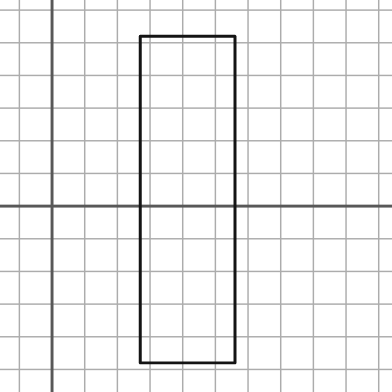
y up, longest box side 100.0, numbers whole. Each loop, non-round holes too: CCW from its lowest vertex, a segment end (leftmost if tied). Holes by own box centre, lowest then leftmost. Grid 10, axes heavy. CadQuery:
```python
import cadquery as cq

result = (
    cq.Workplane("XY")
    .moveTo(27.0, -48.0)
    .lineTo(56.0, -48.0)
    .lineTo(56.0, 52.0)
    .lineTo(27.0, 52.0)
    .close()
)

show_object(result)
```